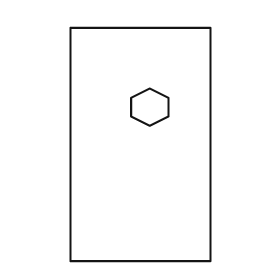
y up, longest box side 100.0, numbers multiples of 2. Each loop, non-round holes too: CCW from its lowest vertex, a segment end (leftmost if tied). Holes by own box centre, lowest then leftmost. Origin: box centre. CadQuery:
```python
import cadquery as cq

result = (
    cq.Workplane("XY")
    .moveTo(-30.0, -50.0)
    .lineTo(30.0, -50.0)
    .lineTo(30.0, 50.0)
    .lineTo(-30.0, 50.0)
    .close()
    .moveTo(4.0, 8.0)
    .lineTo(12.0, 12.0)
    .lineTo(12.0, 20.0)
    .lineTo(4.0, 24.0)
    .lineTo(-4.0, 20.0)
    .lineTo(-4.0, 12.0)
    .close()
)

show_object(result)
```